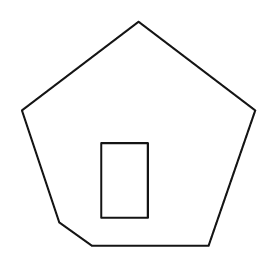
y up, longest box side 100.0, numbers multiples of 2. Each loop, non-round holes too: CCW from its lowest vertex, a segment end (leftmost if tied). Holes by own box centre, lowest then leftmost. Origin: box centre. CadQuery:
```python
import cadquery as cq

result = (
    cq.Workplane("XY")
    .moveTo(-20.0, -48.0)
    .lineTo(30.0, -48.0)
    .lineTo(50.0, 10.0)
    .lineTo(0.0, 48.0)
    .lineTo(-50.0, 10.0)
    .lineTo(-34.0, -38.0)
    .close()
    .moveTo(-16.0, -36.0)
    .lineTo(4.0, -36.0)
    .lineTo(4.0, -4.0)
    .lineTo(-16.0, -4.0)
    .close()
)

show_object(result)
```